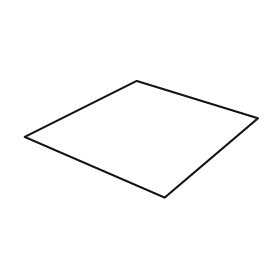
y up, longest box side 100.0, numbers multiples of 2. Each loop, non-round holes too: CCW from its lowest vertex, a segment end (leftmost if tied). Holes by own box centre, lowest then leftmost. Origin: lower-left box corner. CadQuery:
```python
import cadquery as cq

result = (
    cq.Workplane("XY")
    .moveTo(60.0, 0.0)
    .lineTo(100.0, 34.0)
    .lineTo(48.0, 50.0)
    .lineTo(0.0, 26.0)
    .close()
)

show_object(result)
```